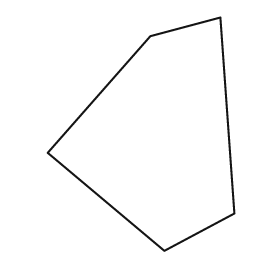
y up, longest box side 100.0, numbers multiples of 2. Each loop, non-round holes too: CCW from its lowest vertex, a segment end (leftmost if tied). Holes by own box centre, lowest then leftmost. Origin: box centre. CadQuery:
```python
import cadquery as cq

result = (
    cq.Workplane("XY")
    .moveTo(10.0, -50.0)
    .lineTo(40.0, -34.0)
    .lineTo(34.0, 50.0)
    .lineTo(4.0, 42.0)
    .lineTo(-40.0, -8.0)
    .close()
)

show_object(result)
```